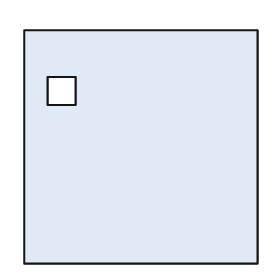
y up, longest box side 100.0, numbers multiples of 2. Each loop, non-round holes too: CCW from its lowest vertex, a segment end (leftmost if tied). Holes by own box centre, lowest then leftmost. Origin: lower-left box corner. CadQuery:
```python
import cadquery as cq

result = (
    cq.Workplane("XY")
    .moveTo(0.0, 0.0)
    .lineTo(100.0, 0.0)
    .lineTo(100.0, 100.0)
    .lineTo(0.0, 100.0)
    .close()
    .moveTo(10.0, 68.0)
    .lineTo(22.0, 68.0)
    .lineTo(22.0, 80.0)
    .lineTo(10.0, 80.0)
    .close()
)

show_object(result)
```